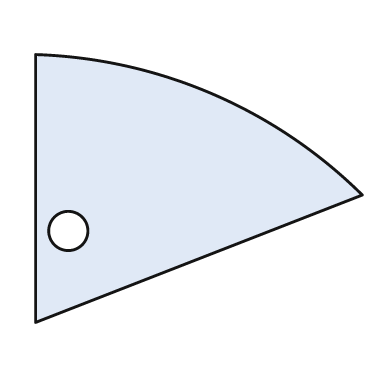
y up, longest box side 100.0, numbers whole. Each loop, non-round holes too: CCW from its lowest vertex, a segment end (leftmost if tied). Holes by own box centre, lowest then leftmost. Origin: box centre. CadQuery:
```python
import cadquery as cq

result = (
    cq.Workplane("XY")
    .moveTo(-50.0, -41.0)
    .lineTo(50.0, -2.0)
    .threePointArc((4.0, 29.0), (-50.0, 41.0))
    .close()
    .moveTo(-40.0, -13.0)
    .circle(6.0)
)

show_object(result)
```